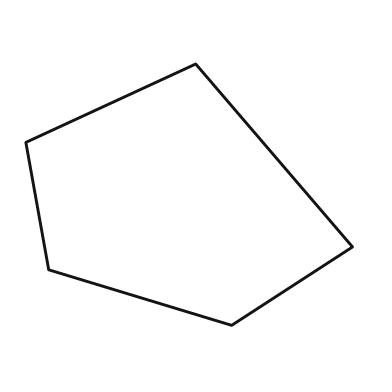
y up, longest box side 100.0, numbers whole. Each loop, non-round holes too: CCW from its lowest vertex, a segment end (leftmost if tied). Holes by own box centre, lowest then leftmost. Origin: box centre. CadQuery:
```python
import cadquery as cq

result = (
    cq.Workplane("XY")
    .moveTo(13.0, -40.0)
    .lineTo(50.0, -16.0)
    .lineTo(2.0, 40.0)
    .lineTo(-50.0, 16.0)
    .lineTo(-43.0, -23.0)
    .close()
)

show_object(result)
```